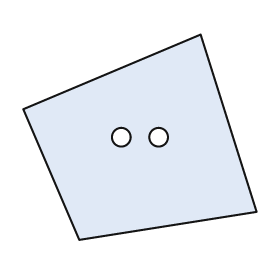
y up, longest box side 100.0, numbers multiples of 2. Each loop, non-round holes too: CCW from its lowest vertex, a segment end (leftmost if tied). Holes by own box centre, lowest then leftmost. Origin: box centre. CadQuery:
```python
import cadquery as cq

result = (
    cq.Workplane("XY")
    .moveTo(-26.0, -44.0)
    .lineTo(50.0, -32.0)
    .lineTo(26.0, 44.0)
    .lineTo(-50.0, 12.0)
    .close()
    .moveTo(-8.0, 0.0)
    .circle(4.0)
    .moveTo(8.0, 0.0)
    .circle(4.0)
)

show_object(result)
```